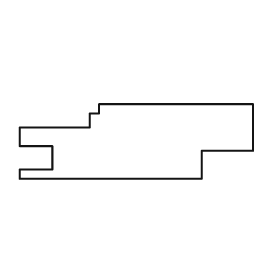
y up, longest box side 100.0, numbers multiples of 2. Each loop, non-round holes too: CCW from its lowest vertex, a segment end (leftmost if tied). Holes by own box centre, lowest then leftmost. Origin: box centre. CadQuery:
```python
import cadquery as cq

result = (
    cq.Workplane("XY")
    .moveTo(-50.0, -16.0)
    .lineTo(28.0, -16.0)
    .lineTo(28.0, -4.0)
    .lineTo(50.0, -4.0)
    .lineTo(50.0, 16.0)
    .lineTo(-16.0, 16.0)
    .lineTo(-16.0, 12.0)
    .lineTo(-20.0, 12.0)
    .lineTo(-20.0, 6.0)
    .lineTo(-50.0, 6.0)
    .lineTo(-50.0, -2.0)
    .lineTo(-36.0, -2.0)
    .lineTo(-36.0, -12.0)
    .lineTo(-50.0, -12.0)
    .close()
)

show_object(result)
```